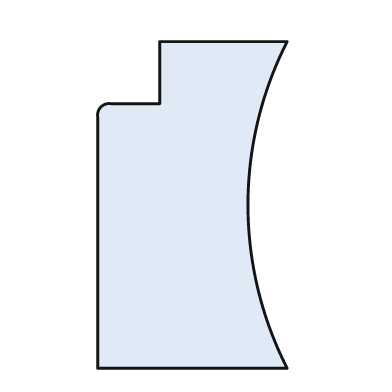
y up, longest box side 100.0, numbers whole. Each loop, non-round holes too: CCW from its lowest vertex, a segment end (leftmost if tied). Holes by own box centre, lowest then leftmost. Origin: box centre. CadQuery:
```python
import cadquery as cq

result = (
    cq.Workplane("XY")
    .moveTo(-29.0, -50.0)
    .lineTo(29.0, -50.0)
    .threePointArc((17.0, 0.0), (29.0, 50.0))
    .lineTo(-10.0, 50.0)
    .lineTo(-10.0, 31.0)
    .lineTo(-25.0, 31.0)
    .threePointArc((-28.0, 30.0), (-29.0, 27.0))
    .close()
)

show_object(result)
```